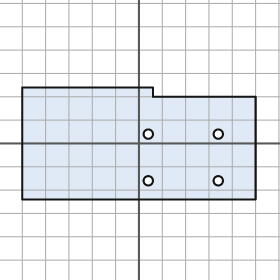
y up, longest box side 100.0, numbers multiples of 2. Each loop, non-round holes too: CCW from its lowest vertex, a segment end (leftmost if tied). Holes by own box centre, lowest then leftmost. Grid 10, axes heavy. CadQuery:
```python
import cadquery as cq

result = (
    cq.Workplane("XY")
    .moveTo(-50.0, -24.0)
    .lineTo(50.0, -24.0)
    .lineTo(50.0, 20.0)
    .lineTo(6.0, 20.0)
    .lineTo(6.0, 24.0)
    .lineTo(-50.0, 24.0)
    .close()
    .moveTo(4.0, -16.0)
    .circle(2.0)
    .moveTo(34.0, -16.0)
    .circle(2.0)
    .moveTo(4.0, 4.0)
    .circle(2.0)
    .moveTo(34.0, 4.0)
    .circle(2.0)
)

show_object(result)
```